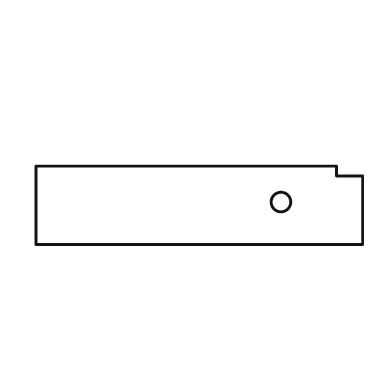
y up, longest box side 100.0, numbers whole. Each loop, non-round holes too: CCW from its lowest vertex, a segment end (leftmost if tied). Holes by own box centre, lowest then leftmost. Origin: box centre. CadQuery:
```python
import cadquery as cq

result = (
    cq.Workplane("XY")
    .moveTo(-50.0, -12.0)
    .lineTo(50.0, -12.0)
    .lineTo(50.0, 9.0)
    .lineTo(42.0, 9.0)
    .lineTo(42.0, 12.0)
    .lineTo(-50.0, 12.0)
    .close()
    .moveTo(25.0, 1.0)
    .circle(3.0)
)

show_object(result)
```